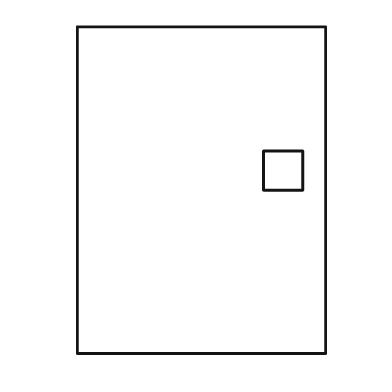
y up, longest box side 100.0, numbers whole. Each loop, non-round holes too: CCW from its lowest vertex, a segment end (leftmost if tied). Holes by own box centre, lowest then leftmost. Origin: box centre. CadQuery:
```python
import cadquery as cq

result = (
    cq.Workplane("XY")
    .moveTo(-38.0, -50.0)
    .lineTo(38.0, -50.0)
    .lineTo(38.0, 50.0)
    .lineTo(-38.0, 50.0)
    .close()
    .moveTo(19.0, 0.0)
    .lineTo(31.0, 0.0)
    .lineTo(31.0, 12.0)
    .lineTo(19.0, 12.0)
    .close()
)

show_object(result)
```